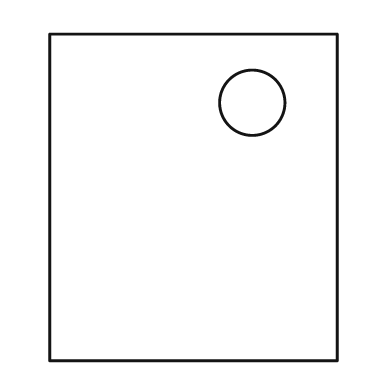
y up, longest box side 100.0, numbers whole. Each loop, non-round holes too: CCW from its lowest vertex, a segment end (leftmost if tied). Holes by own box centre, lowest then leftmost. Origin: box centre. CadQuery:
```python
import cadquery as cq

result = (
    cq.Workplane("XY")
    .moveTo(-44.0, -50.0)
    .lineTo(44.0, -50.0)
    .lineTo(44.0, 50.0)
    .lineTo(-44.0, 50.0)
    .close()
    .moveTo(18.0, 29.0)
    .circle(10.0)
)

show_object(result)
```